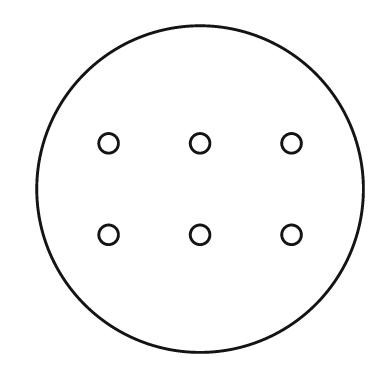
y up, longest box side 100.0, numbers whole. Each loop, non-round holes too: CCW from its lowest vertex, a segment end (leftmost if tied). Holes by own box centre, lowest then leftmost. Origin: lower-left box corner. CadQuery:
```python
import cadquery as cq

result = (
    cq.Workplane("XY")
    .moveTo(50.0, 50.0)
    .circle(50.0)
    .moveTo(22.0, 36.0)
    .circle(3.0)
    .moveTo(50.0, 36.0)
    .circle(3.0)
    .moveTo(78.0, 36.0)
    .circle(3.0)
    .moveTo(22.0, 64.0)
    .circle(3.0)
    .moveTo(50.0, 64.0)
    .circle(3.0)
    .moveTo(78.0, 64.0)
    .circle(3.0)
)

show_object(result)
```